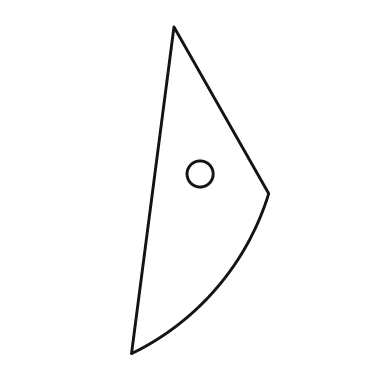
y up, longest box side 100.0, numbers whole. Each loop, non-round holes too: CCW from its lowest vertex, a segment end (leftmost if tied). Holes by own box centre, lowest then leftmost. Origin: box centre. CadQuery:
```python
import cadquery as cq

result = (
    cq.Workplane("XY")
    .moveTo(-21.0, -50.0)
    .threePointArc((5.0, -30.0), (21.0, -1.0))
    .lineTo(-8.0, 50.0)
    .close()
    .moveTo(0.0, 5.0)
    .circle(4.0)
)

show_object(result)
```